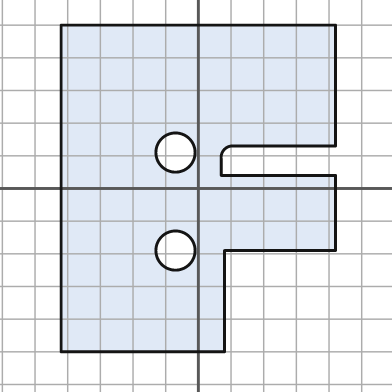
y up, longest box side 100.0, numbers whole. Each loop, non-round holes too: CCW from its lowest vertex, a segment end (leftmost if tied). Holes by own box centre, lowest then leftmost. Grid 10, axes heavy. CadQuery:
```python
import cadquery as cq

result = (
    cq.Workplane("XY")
    .moveTo(-42.0, -50.0)
    .lineTo(8.0, -50.0)
    .lineTo(8.0, -19.0)
    .lineTo(42.0, -19.0)
    .lineTo(42.0, 4.0)
    .lineTo(7.0, 4.0)
    .lineTo(7.0, 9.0)
    .threePointArc((8.0, 12.0), (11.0, 13.0))
    .lineTo(42.0, 13.0)
    .lineTo(42.0, 50.0)
    .lineTo(-42.0, 50.0)
    .close()
    .moveTo(-7.0, -19.0)
    .circle(6.0)
    .moveTo(-7.0, 11.0)
    .circle(6.0)
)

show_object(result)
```